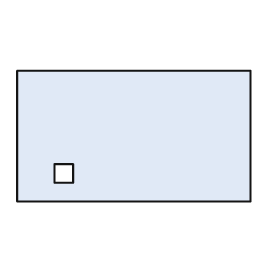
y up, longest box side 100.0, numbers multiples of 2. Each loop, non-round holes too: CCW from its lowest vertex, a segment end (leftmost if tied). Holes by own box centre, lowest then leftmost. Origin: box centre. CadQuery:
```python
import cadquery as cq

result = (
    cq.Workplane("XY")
    .moveTo(-50.0, -28.0)
    .lineTo(50.0, -28.0)
    .lineTo(50.0, 28.0)
    .lineTo(-50.0, 28.0)
    .close()
    .moveTo(-34.0, -20.0)
    .lineTo(-26.0, -20.0)
    .lineTo(-26.0, -12.0)
    .lineTo(-34.0, -12.0)
    .close()
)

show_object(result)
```